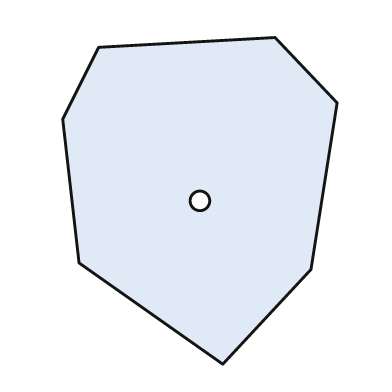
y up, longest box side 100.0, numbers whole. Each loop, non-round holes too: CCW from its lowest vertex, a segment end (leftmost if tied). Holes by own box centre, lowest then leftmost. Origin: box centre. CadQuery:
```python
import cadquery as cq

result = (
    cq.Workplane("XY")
    .moveTo(7.0, -50.0)
    .lineTo(34.0, -21.0)
    .lineTo(42.0, 30.0)
    .lineTo(23.0, 50.0)
    .lineTo(-31.0, 47.0)
    .lineTo(-42.0, 25.0)
    .lineTo(-37.0, -19.0)
    .close()
    .moveTo(0.0, 0.0)
    .circle(3.0)
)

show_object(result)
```